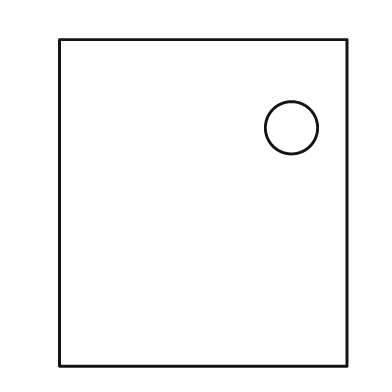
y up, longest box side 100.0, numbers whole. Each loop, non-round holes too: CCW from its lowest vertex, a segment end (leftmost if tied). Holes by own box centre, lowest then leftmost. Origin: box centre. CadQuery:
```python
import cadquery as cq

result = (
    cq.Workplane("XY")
    .moveTo(-44.0, -50.0)
    .lineTo(44.0, -50.0)
    .lineTo(44.0, 50.0)
    .lineTo(-44.0, 50.0)
    .close()
    .moveTo(27.0, 23.0)
    .circle(8.0)
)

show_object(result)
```